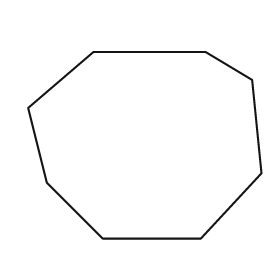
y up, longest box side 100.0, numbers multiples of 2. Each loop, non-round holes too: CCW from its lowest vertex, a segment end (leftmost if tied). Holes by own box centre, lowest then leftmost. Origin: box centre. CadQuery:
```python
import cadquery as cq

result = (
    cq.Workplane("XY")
    .moveTo(-18.0, -40.0)
    .lineTo(24.0, -40.0)
    .lineTo(50.0, -12.0)
    .lineTo(46.0, 28.0)
    .lineTo(26.0, 40.0)
    .lineTo(-22.0, 40.0)
    .lineTo(-50.0, 16.0)
    .lineTo(-42.0, -16.0)
    .close()
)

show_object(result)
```